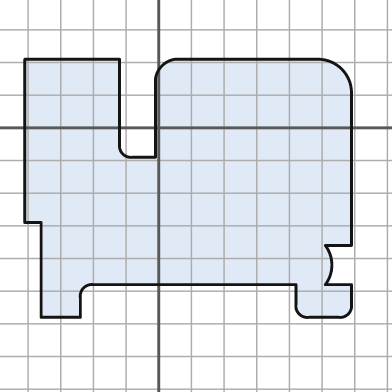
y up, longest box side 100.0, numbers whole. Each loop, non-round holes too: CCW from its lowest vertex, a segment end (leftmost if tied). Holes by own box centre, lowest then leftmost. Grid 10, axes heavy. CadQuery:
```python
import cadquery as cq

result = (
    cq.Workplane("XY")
    .moveTo(-36.0, -58.0)
    .lineTo(-24.0, -58.0)
    .lineTo(-24.0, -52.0)
    .threePointArc((-23.0, -49.0), (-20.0, -48.0))
    .lineTo(42.0, -48.0)
    .lineTo(42.0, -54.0)
    .threePointArc((43.0, -57.0), (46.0, -58.0))
    .lineTo(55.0, -58.0)
    .threePointArc((58.0, -57.0), (59.0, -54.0))
    .lineTo(59.0, -48.0)
    .lineTo(51.0, -48.0)
    .threePointArc((53.0, -42.0), (51.0, -36.0))
    .lineTo(59.0, -36.0)
    .lineTo(59.0, 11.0)
    .threePointArc((56.0, 18.0), (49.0, 21.0))
    .lineTo(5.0, 21.0)
    .threePointArc((1.0, 19.0), (-1.0, 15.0))
    .lineTo(-1.0, -9.0)
    .lineTo(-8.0, -9.0)
    .threePointArc((-11.0, -8.0), (-12.0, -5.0))
    .lineTo(-12.0, 21.0)
    .lineTo(-41.0, 21.0)
    .lineTo(-41.0, -29.0)
    .lineTo(-36.0, -29.0)
    .close()
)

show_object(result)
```